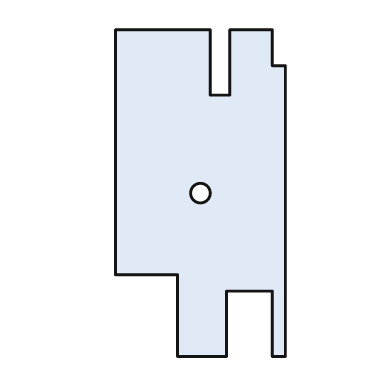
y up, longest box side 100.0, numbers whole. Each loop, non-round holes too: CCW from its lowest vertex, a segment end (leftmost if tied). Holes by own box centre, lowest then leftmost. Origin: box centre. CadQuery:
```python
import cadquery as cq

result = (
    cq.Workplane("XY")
    .moveTo(-7.0, -50.0)
    .lineTo(8.0, -50.0)
    .lineTo(8.0, -30.0)
    .lineTo(22.0, -30.0)
    .lineTo(22.0, -50.0)
    .lineTo(26.0, -50.0)
    .lineTo(26.0, 39.0)
    .lineTo(22.0, 39.0)
    .lineTo(22.0, 50.0)
    .lineTo(9.0, 50.0)
    .lineTo(9.0, 30.0)
    .lineTo(3.0, 30.0)
    .lineTo(3.0, 50.0)
    .lineTo(-26.0, 50.0)
    .lineTo(-26.0, -25.0)
    .lineTo(-7.0, -25.0)
    .close()
    .moveTo(0.0, 0.0)
    .circle(3.0)
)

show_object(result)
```